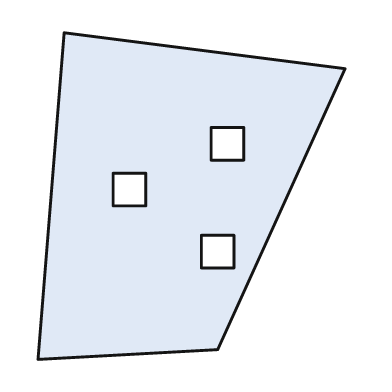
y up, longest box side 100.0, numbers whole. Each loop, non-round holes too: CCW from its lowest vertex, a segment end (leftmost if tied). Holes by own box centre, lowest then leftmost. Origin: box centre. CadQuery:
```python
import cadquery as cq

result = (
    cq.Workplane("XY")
    .moveTo(-47.0, -50.0)
    .lineTo(8.0, -47.0)
    .lineTo(47.0, 39.0)
    .lineTo(-39.0, 50.0)
    .close()
    .moveTo(3.0, -22.0)
    .lineTo(13.0, -22.0)
    .lineTo(13.0, -12.0)
    .lineTo(3.0, -12.0)
    .close()
    .moveTo(-24.0, -3.0)
    .lineTo(-14.0, -3.0)
    .lineTo(-14.0, 7.0)
    .lineTo(-24.0, 7.0)
    .close()
    .moveTo(6.0, 11.0)
    .lineTo(16.0, 11.0)
    .lineTo(16.0, 21.0)
    .lineTo(6.0, 21.0)
    .close()
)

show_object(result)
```